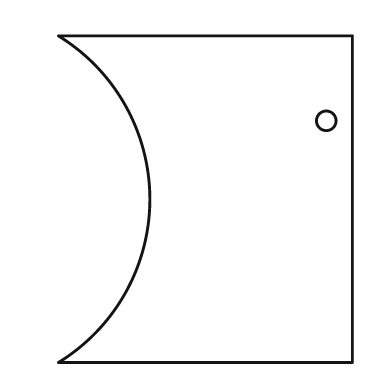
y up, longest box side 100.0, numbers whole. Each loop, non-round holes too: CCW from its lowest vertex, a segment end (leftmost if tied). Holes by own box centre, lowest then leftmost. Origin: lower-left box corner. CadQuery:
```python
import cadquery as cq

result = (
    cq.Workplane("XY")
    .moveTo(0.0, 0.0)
    .lineTo(90.0, 0.0)
    .lineTo(90.0, 100.0)
    .lineTo(0.0, 100.0)
    .threePointArc((28.0, 50.0), (0.0, 0.0))
    .close()
    .moveTo(82.0, 74.0)
    .circle(3.0)
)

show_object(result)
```